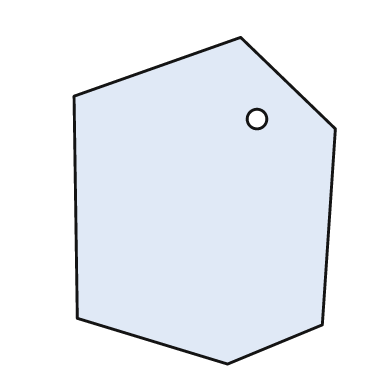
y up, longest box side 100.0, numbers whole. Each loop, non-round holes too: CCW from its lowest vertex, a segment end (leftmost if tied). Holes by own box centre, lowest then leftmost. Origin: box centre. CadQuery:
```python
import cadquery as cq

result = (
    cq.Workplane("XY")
    .moveTo(7.0, -50.0)
    .lineTo(36.0, -38.0)
    .lineTo(40.0, 22.0)
    .lineTo(11.0, 50.0)
    .lineTo(-40.0, 32.0)
    .lineTo(-39.0, -36.0)
    .close()
    .moveTo(16.0, 25.0)
    .circle(3.0)
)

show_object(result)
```